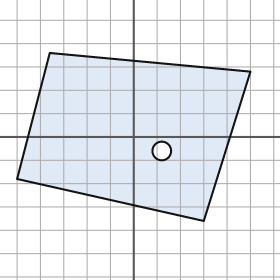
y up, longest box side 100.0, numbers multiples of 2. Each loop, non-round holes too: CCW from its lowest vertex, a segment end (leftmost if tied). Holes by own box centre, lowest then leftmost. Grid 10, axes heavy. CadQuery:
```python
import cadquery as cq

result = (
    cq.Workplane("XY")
    .moveTo(30.0, -36.0)
    .lineTo(50.0, 28.0)
    .lineTo(-36.0, 36.0)
    .lineTo(-50.0, -18.0)
    .close()
    .moveTo(12.0, -6.0)
    .circle(4.0)
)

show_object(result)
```